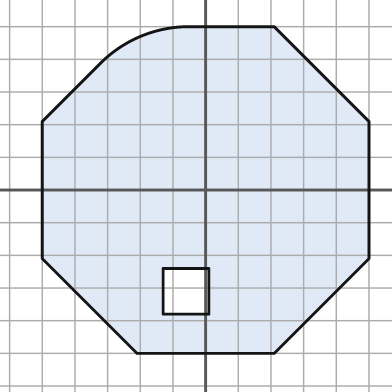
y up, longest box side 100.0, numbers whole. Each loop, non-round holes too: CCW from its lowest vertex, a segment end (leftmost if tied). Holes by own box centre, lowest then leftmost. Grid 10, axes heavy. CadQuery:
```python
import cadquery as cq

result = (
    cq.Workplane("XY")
    .moveTo(-21.0, -50.0)
    .lineTo(21.0, -50.0)
    .lineTo(50.0, -21.0)
    .lineTo(50.0, 21.0)
    .lineTo(21.0, 50.0)
    .lineTo(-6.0, 50.0)
    .threePointArc((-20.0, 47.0), (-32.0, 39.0))
    .lineTo(-50.0, 21.0)
    .lineTo(-50.0, -21.0)
    .close()
    .moveTo(-13.0, -38.0)
    .lineTo(1.0, -38.0)
    .lineTo(1.0, -24.0)
    .lineTo(-13.0, -24.0)
    .close()
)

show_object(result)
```